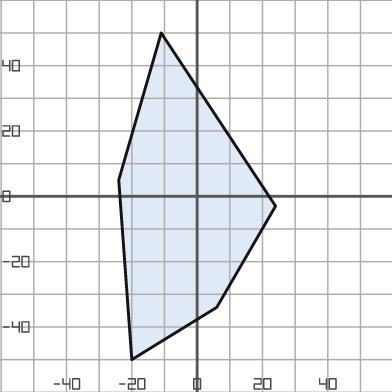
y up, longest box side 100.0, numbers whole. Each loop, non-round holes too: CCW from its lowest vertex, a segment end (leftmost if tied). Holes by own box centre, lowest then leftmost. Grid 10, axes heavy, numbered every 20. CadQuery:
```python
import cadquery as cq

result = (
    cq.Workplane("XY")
    .moveTo(-20.0, -50.0)
    .lineTo(6.0, -34.0)
    .lineTo(24.0, -3.0)
    .lineTo(-11.0, 50.0)
    .lineTo(-24.0, 5.0)
    .close()
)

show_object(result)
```